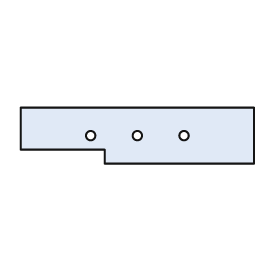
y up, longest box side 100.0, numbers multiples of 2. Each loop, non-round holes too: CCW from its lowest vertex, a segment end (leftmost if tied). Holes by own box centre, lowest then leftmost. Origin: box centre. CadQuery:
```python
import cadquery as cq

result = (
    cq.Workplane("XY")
    .moveTo(-14.0, -12.0)
    .lineTo(50.0, -12.0)
    .lineTo(50.0, 12.0)
    .lineTo(-50.0, 12.0)
    .lineTo(-50.0, -6.0)
    .lineTo(-14.0, -6.0)
    .close()
    .moveTo(-20.0, 0.0)
    .circle(2.0)
    .moveTo(0.0, 0.0)
    .circle(2.0)
    .moveTo(20.0, 0.0)
    .circle(2.0)
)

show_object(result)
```